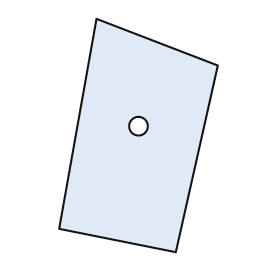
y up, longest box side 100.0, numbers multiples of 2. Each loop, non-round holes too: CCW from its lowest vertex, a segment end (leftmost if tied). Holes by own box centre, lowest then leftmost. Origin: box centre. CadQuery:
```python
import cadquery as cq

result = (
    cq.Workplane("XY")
    .moveTo(16.0, -50.0)
    .lineTo(34.0, 30.0)
    .lineTo(-18.0, 50.0)
    .lineTo(-34.0, -40.0)
    .close()
    .moveTo(0.0, 4.0)
    .circle(4.0)
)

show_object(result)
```